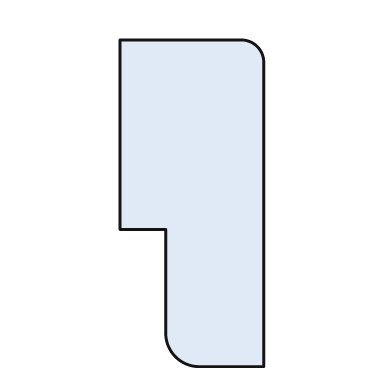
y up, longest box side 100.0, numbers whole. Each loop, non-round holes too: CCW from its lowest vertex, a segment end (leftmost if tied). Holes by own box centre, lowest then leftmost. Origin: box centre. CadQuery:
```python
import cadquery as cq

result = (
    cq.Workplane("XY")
    .moveTo(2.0, -50.0)
    .lineTo(22.0, -50.0)
    .lineTo(22.0, 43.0)
    .threePointArc((20.0, 48.0), (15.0, 50.0))
    .lineTo(-22.0, 50.0)
    .lineTo(-22.0, -8.0)
    .lineTo(-8.0, -8.0)
    .lineTo(-8.0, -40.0)
    .threePointArc((-5.0, -47.0), (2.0, -50.0))
    .close()
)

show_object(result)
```